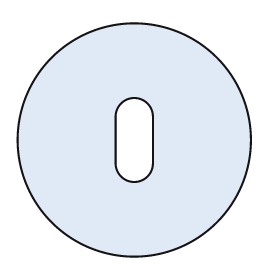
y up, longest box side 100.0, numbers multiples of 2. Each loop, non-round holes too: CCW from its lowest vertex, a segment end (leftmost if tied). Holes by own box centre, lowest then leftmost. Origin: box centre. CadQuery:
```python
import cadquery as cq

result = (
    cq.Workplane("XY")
    .moveTo(0.0, 0.0)
    .circle(50.0)
    .moveTo(-8.0, -10.0)
    .threePointArc((0.0, -18.0), (8.0, -10.0))
    .lineTo(8.0, 10.0)
    .threePointArc((0.0, 18.0), (-8.0, 10.0))
    .close()
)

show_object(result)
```